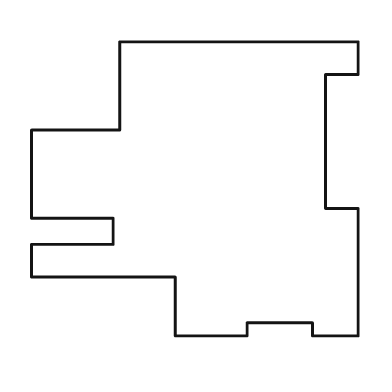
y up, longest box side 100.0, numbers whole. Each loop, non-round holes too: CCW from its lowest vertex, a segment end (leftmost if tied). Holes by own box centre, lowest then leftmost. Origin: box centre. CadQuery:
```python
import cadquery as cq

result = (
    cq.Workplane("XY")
    .moveTo(-6.0, -45.0)
    .lineTo(16.0, -45.0)
    .lineTo(16.0, -41.0)
    .lineTo(36.0, -41.0)
    .lineTo(36.0, -45.0)
    .lineTo(50.0, -45.0)
    .lineTo(50.0, -6.0)
    .lineTo(40.0, -6.0)
    .lineTo(40.0, 35.0)
    .lineTo(50.0, 35.0)
    .lineTo(50.0, 45.0)
    .lineTo(-23.0, 45.0)
    .lineTo(-23.0, 18.0)
    .lineTo(-50.0, 18.0)
    .lineTo(-50.0, -9.0)
    .lineTo(-25.0, -9.0)
    .lineTo(-25.0, -17.0)
    .lineTo(-50.0, -17.0)
    .lineTo(-50.0, -27.0)
    .lineTo(-6.0, -27.0)
    .close()
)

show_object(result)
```